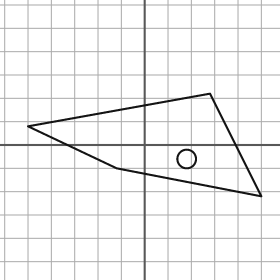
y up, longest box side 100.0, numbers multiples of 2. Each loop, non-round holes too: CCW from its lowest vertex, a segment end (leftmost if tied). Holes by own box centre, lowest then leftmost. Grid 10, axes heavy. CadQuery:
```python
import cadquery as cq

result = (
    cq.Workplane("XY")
    .moveTo(50.0, -22.0)
    .lineTo(28.0, 22.0)
    .lineTo(-50.0, 8.0)
    .lineTo(-12.0, -10.0)
    .close()
    .moveTo(18.0, -6.0)
    .circle(4.0)
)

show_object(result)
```